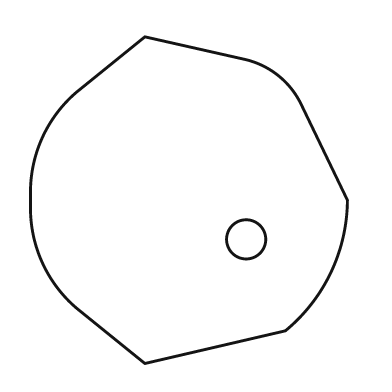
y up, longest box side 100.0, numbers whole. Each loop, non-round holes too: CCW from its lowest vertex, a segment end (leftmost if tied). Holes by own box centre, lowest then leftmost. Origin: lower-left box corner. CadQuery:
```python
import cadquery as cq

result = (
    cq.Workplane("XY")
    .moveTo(35.0, 0.0)
    .lineTo(78.0, 10.0)
    .threePointArc((92.0, 28.0), (97.0, 50.0))
    .lineTo(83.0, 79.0)
    .threePointArc((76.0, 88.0), (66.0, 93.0))
    .lineTo(35.0, 100.0)
    .lineTo(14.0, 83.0)
    .threePointArc((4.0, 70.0), (0.0, 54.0))
    .lineTo(0.0, 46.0)
    .threePointArc((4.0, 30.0), (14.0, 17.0))
    .close()
    .moveTo(66.0, 38.0)
    .circle(6.0)
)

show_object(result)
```